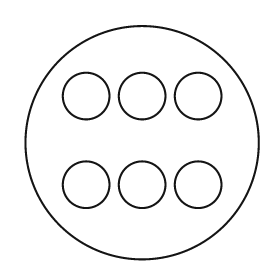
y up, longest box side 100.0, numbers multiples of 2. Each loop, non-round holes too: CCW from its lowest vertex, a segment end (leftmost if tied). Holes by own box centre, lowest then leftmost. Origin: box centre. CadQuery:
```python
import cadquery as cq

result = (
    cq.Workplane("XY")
    .moveTo(0.0, 0.0)
    .circle(50.0)
    .moveTo(-24.0, -18.0)
    .circle(10.0)
    .moveTo(0.0, -18.0)
    .circle(10.0)
    .moveTo(24.0, -18.0)
    .circle(10.0)
    .moveTo(-24.0, 20.0)
    .circle(10.0)
    .moveTo(0.0, 20.0)
    .circle(10.0)
    .moveTo(24.0, 20.0)
    .circle(10.0)
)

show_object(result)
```